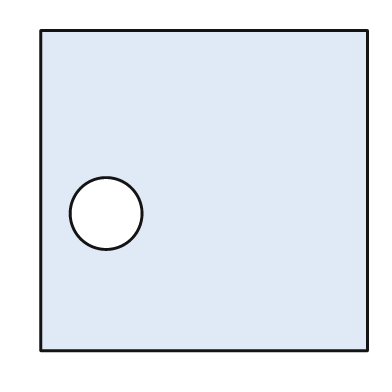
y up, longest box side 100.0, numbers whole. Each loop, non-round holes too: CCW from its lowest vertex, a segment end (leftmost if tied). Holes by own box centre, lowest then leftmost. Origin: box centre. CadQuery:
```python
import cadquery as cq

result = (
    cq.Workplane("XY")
    .moveTo(-50.0, -49.0)
    .lineTo(50.0, -49.0)
    .lineTo(50.0, 49.0)
    .lineTo(-50.0, 49.0)
    .close()
    .moveTo(-30.0, -7.0)
    .circle(11.0)
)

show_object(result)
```